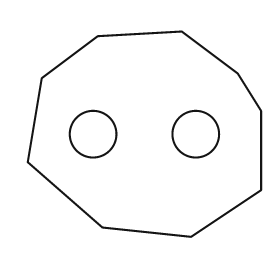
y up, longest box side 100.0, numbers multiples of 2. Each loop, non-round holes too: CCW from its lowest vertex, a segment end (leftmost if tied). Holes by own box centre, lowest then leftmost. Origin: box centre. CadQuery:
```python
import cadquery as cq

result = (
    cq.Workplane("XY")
    .moveTo(20.0, -44.0)
    .lineTo(50.0, -24.0)
    .lineTo(50.0, 10.0)
    .lineTo(40.0, 26.0)
    .lineTo(16.0, 44.0)
    .lineTo(-20.0, 42.0)
    .lineTo(-44.0, 24.0)
    .lineTo(-50.0, -12.0)
    .lineTo(-18.0, -40.0)
    .close()
    .moveTo(-22.0, 0.0)
    .circle(10.0)
    .moveTo(22.0, 0.0)
    .circle(10.0)
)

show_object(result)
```